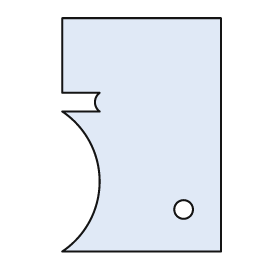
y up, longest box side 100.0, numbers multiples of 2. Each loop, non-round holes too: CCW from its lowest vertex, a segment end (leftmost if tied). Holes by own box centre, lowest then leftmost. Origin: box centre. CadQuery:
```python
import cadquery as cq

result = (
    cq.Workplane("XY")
    .moveTo(-34.0, -50.0)
    .lineTo(34.0, -50.0)
    .lineTo(34.0, 50.0)
    .lineTo(-34.0, 50.0)
    .lineTo(-34.0, 18.0)
    .lineTo(-18.0, 18.0)
    .threePointArc((-20.0, 14.0), (-18.0, 10.0))
    .lineTo(-34.0, 10.0)
    .threePointArc((-18.0, -20.0), (-34.0, -50.0))
    .close()
    .moveTo(18.0, -32.0)
    .circle(4.0)
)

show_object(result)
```